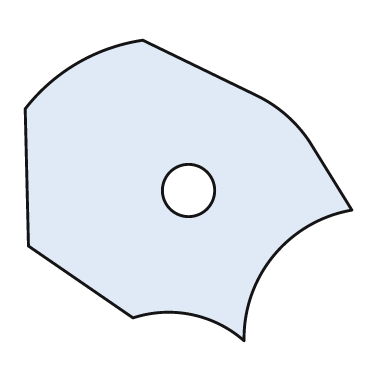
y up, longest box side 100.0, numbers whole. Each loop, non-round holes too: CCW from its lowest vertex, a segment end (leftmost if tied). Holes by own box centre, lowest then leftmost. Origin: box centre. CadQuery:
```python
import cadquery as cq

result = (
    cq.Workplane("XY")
    .moveTo(17.0, -46.0)
    .threePointArc((26.0, -20.0), (50.0, -6.0))
    .lineTo(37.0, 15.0)
    .threePointArc((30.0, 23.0), (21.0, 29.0))
    .lineTo(-14.0, 46.0)
    .threePointArc((-34.0, 39.0), (-50.0, 25.0))
    .lineTo(-49.0, -17.0)
    .lineTo(-17.0, -39.0)
    .threePointArc((1.0, -38.0), (17.0, -46.0))
    .close()
    .moveTo(0.0, 0.0)
    .circle(8.0)
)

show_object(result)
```